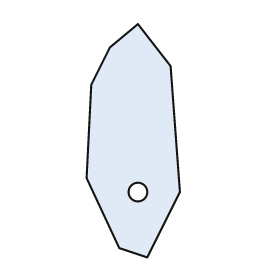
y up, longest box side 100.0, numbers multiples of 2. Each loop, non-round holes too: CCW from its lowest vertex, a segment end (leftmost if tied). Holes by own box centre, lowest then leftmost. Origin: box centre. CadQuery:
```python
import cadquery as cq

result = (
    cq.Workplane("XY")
    .moveTo(6.0, -50.0)
    .lineTo(20.0, -22.0)
    .lineTo(16.0, 32.0)
    .lineTo(2.0, 50.0)
    .lineTo(-10.0, 40.0)
    .lineTo(-18.0, 24.0)
    .lineTo(-20.0, -16.0)
    .lineTo(-6.0, -46.0)
    .close()
    .moveTo(2.0, -22.0)
    .circle(4.0)
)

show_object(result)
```